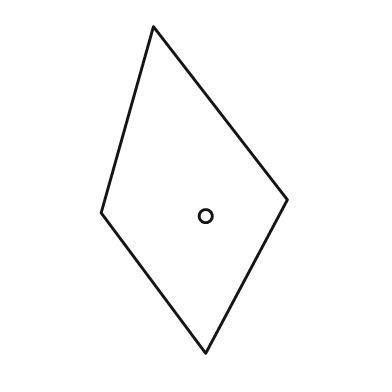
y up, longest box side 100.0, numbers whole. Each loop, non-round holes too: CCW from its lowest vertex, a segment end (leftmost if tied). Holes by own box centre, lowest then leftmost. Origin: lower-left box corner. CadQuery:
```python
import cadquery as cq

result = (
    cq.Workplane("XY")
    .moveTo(32.0, 0.0)
    .lineTo(57.0, 47.0)
    .lineTo(16.0, 100.0)
    .lineTo(0.0, 43.0)
    .close()
    .moveTo(32.0, 42.0)
    .circle(2.0)
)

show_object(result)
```